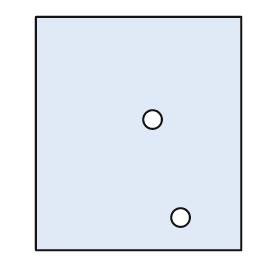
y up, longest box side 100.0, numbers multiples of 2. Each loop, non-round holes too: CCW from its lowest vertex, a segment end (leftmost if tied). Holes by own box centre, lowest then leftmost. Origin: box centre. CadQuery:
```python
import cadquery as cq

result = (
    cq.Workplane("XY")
    .moveTo(-44.0, -50.0)
    .lineTo(44.0, -50.0)
    .lineTo(44.0, 50.0)
    .lineTo(-44.0, 50.0)
    .close()
    .moveTo(18.0, -36.0)
    .circle(4.0)
    .moveTo(6.0, 6.0)
    .circle(4.0)
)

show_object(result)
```